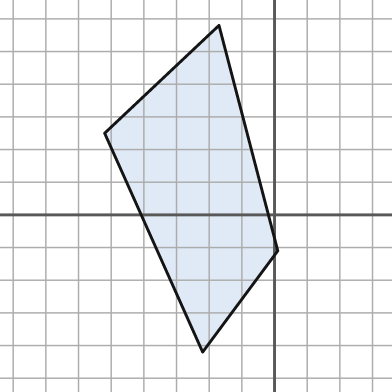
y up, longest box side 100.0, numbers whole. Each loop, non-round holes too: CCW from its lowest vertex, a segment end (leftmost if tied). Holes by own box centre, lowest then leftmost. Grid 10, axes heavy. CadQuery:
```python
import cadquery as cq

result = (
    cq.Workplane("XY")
    .moveTo(-22.0, -42.0)
    .lineTo(1.0, -11.0)
    .lineTo(-17.0, 58.0)
    .lineTo(-52.0, 25.0)
    .close()
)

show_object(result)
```